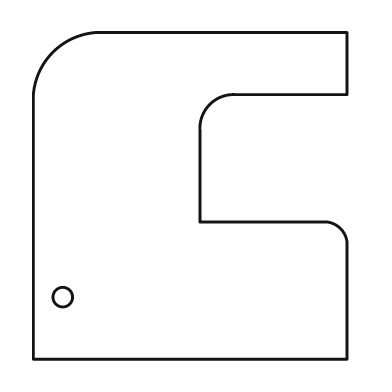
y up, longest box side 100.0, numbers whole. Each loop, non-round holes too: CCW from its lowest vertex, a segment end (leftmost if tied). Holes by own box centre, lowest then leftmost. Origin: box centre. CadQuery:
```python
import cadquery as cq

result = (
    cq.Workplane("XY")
    .moveTo(-48.0, -50.0)
    .lineTo(48.0, -50.0)
    .lineTo(48.0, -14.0)
    .threePointArc((46.0, -10.0), (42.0, -8.0))
    .lineTo(3.0, -8.0)
    .lineTo(3.0, 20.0)
    .threePointArc((6.0, 28.0), (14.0, 31.0))
    .lineTo(48.0, 31.0)
    .lineTo(48.0, 50.0)
    .lineTo(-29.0, 50.0)
    .threePointArc((-42.0, 44.0), (-48.0, 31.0))
    .close()
    .moveTo(-39.0, -31.0)
    .circle(3.0)
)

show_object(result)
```